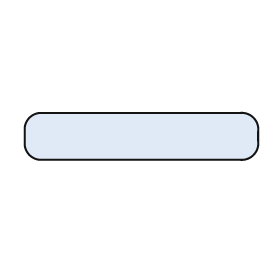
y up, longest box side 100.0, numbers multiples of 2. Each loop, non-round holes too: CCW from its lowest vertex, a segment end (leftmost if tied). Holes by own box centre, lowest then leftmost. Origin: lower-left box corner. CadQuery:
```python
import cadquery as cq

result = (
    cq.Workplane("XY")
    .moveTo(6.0, 0.0)
    .lineTo(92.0, 0.0)
    .threePointArc((98.0, 2.0), (100.0, 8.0))
    .lineTo(100.0, 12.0)
    .threePointArc((98.0, 18.0), (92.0, 20.0))
    .lineTo(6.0, 20.0)
    .threePointArc((2.0, 18.0), (0.0, 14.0))
    .lineTo(0.0, 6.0)
    .threePointArc((2.0, 2.0), (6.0, 0.0))
    .close()
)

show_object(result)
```